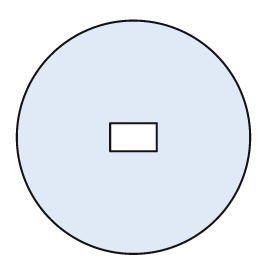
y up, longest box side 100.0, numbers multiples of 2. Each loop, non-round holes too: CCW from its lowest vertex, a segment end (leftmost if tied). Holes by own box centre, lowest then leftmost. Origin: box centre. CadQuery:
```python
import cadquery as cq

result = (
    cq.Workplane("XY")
    .moveTo(0.0, 0.0)
    .circle(50.0)
    .moveTo(-10.0, -6.0)
    .lineTo(10.0, -6.0)
    .lineTo(10.0, 6.0)
    .lineTo(-10.0, 6.0)
    .close()
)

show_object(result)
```